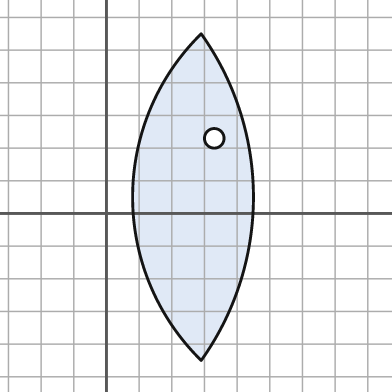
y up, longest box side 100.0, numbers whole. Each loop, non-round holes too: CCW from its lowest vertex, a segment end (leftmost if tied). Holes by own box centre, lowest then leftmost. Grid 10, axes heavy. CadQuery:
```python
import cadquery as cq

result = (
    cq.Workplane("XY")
    .moveTo(29.0, -45.0)
    .threePointArc((45.0, 5.0), (29.0, 55.0))
    .threePointArc((8.0, 5.0), (29.0, -45.0))
    .close()
    .moveTo(33.0, 23.0)
    .circle(3.0)
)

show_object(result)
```